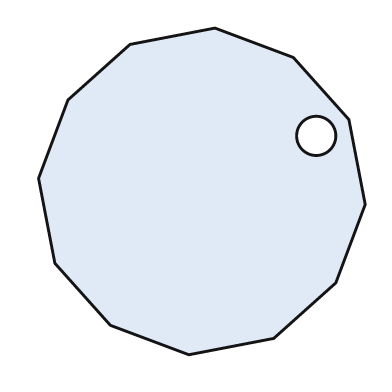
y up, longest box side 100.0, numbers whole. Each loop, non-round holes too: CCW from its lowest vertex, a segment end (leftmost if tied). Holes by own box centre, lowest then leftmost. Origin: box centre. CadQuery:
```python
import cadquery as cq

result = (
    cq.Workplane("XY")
    .moveTo(-4.0, -50.0)
    .lineTo(22.0, -45.0)
    .lineTo(41.0, -28.0)
    .lineTo(50.0, -4.0)
    .lineTo(45.0, 22.0)
    .lineTo(28.0, 41.0)
    .lineTo(4.0, 50.0)
    .lineTo(-22.0, 45.0)
    .lineTo(-41.0, 28.0)
    .lineTo(-50.0, 4.0)
    .lineTo(-45.0, -22.0)
    .lineTo(-28.0, -41.0)
    .close()
    .moveTo(35.0, 17.0)
    .circle(6.0)
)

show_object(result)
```